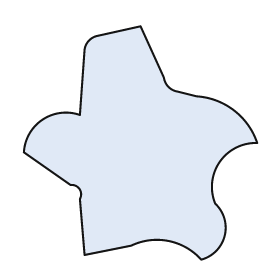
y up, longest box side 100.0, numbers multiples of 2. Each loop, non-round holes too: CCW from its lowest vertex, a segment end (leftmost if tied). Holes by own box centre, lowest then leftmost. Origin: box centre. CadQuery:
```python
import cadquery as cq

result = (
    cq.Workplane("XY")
    .moveTo(26.0, -50.0)
    .threePointArc((36.0, -40.0), (32.0, -26.0))
    .threePointArc((34.0, -8.0), (50.0, 0.0))
    .threePointArc((40.0, 14.0), (24.0, 20.0))
    .lineTo(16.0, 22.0)
    .threePointArc((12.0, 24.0), (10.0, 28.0))
    .lineTo(0.0, 50.0)
    .lineTo(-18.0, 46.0)
    .threePointArc((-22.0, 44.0), (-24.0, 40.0))
    .lineTo(-26.0, 12.0)
    .threePointArc((-42.0, 10.0), (-50.0, -4.0))
    .lineTo(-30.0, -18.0)
    .threePointArc((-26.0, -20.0), (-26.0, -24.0))
    .lineTo(-24.0, -48.0)
    .lineTo(-4.0, -44.0)
    .threePointArc((12.0, -42.0), (26.0, -50.0))
    .close()
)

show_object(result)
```